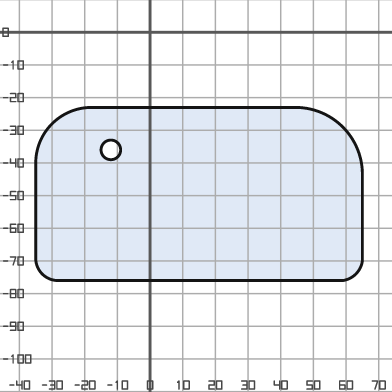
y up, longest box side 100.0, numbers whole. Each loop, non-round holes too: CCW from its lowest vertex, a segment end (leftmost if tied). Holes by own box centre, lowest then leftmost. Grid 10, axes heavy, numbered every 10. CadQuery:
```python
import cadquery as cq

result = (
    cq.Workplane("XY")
    .moveTo(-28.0, -76.0)
    .lineTo(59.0, -76.0)
    .threePointArc((63.0, -74.0), (65.0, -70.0))
    .lineTo(65.0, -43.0)
    .threePointArc((59.0, -29.0), (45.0, -23.0))
    .lineTo(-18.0, -23.0)
    .threePointArc((-30.0, -28.0), (-35.0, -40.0))
    .lineTo(-35.0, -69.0)
    .threePointArc((-33.0, -74.0), (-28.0, -76.0))
    .close()
    .moveTo(-12.0, -36.0)
    .circle(3.0)
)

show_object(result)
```